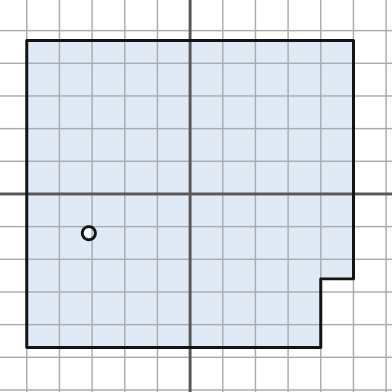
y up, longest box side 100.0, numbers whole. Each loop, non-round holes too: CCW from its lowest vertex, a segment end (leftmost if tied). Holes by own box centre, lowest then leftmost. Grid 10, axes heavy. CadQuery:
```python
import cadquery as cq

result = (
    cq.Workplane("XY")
    .moveTo(-50.0, -47.0)
    .lineTo(40.0, -47.0)
    .lineTo(40.0, -26.0)
    .lineTo(50.0, -26.0)
    .lineTo(50.0, 47.0)
    .lineTo(-50.0, 47.0)
    .close()
    .moveTo(-31.0, -12.0)
    .circle(2.0)
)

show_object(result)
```